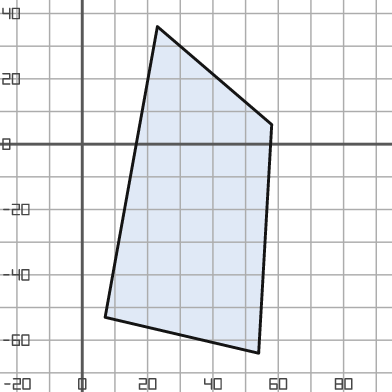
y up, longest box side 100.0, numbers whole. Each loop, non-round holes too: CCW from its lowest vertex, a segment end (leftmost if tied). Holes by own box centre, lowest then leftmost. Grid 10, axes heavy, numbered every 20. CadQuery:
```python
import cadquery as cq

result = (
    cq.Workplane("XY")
    .moveTo(54.0, -64.0)
    .lineTo(58.0, 6.0)
    .lineTo(23.0, 36.0)
    .lineTo(7.0, -53.0)
    .close()
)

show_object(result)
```